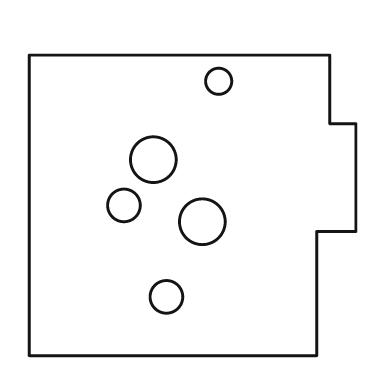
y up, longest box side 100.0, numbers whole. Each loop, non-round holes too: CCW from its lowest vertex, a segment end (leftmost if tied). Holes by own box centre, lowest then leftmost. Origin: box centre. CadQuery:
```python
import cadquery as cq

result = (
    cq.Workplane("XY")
    .moveTo(-50.0, -46.0)
    .lineTo(38.0, -46.0)
    .lineTo(38.0, -8.0)
    .lineTo(50.0, -8.0)
    .lineTo(50.0, 25.0)
    .lineTo(42.0, 25.0)
    .lineTo(42.0, 46.0)
    .lineTo(-50.0, 46.0)
    .close()
    .moveTo(-8.0, -28.0)
    .circle(5.0)
    .moveTo(3.0, -5.0)
    .circle(7.0)
    .moveTo(-21.0, 0.0)
    .circle(5.0)
    .moveTo(-12.0, 14.0)
    .circle(7.0)
    .moveTo(8.0, 38.0)
    .circle(4.0)
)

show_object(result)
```